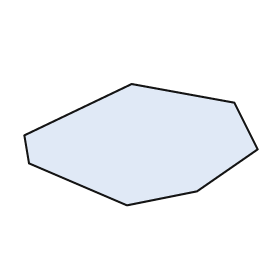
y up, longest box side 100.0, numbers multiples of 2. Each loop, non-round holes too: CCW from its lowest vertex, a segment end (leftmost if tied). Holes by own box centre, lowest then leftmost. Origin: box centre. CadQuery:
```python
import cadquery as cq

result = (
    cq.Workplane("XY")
    .moveTo(-6.0, -26.0)
    .lineTo(24.0, -20.0)
    .lineTo(50.0, -2.0)
    .lineTo(40.0, 18.0)
    .lineTo(-4.0, 26.0)
    .lineTo(-50.0, 4.0)
    .lineTo(-48.0, -8.0)
    .close()
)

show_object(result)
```